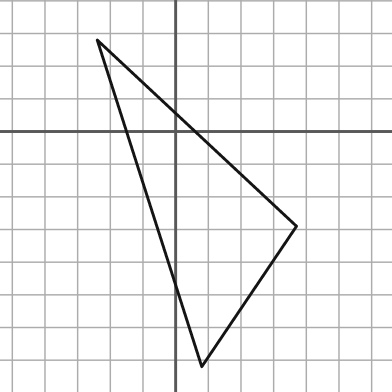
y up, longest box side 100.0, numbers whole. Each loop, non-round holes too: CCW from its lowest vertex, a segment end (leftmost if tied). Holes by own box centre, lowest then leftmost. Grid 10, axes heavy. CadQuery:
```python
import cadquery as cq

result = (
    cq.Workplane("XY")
    .moveTo(8.0, -72.0)
    .lineTo(37.0, -29.0)
    .lineTo(-24.0, 28.0)
    .close()
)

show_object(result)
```